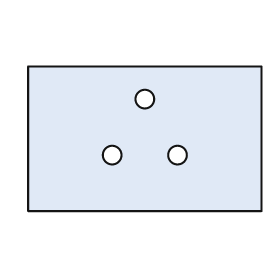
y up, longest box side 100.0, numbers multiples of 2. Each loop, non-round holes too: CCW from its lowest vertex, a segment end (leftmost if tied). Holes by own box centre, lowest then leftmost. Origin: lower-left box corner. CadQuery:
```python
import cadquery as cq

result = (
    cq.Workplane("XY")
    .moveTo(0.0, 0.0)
    .lineTo(100.0, 0.0)
    .lineTo(100.0, 62.0)
    .lineTo(0.0, 62.0)
    .close()
    .moveTo(36.0, 24.0)
    .circle(4.0)
    .moveTo(64.0, 24.0)
    .circle(4.0)
    .moveTo(50.0, 48.0)
    .circle(4.0)
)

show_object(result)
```